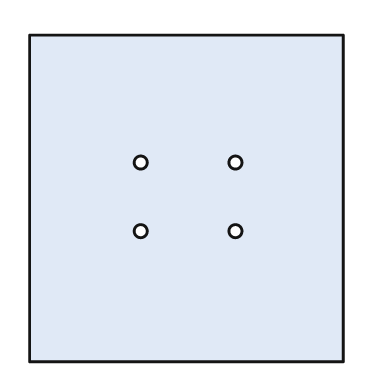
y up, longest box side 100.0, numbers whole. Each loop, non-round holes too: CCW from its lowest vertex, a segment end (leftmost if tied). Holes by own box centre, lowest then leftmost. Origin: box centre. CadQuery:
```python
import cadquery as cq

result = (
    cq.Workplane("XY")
    .moveTo(-48.0, -50.0)
    .lineTo(48.0, -50.0)
    .lineTo(48.0, 50.0)
    .lineTo(-48.0, 50.0)
    .close()
    .moveTo(-14.0, -10.0)
    .circle(2.0)
    .moveTo(15.0, -10.0)
    .circle(2.0)
    .moveTo(-14.0, 11.0)
    .circle(2.0)
    .moveTo(15.0, 11.0)
    .circle(2.0)
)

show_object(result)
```